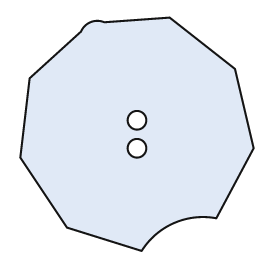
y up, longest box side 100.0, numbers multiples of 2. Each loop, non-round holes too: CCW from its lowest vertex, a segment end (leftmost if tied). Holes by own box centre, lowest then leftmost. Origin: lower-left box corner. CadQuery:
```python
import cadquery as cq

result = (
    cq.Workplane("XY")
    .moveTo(52.0, 0.0)
    .threePointArc((66.0, 12.0), (84.0, 14.0))
    .lineTo(100.0, 44.0)
    .lineTo(92.0, 78.0)
    .lineTo(64.0, 100.0)
    .lineTo(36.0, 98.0)
    .threePointArc((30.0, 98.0), (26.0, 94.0))
    .lineTo(4.0, 74.0)
    .lineTo(0.0, 40.0)
    .lineTo(20.0, 10.0)
    .close()
    .moveTo(50.0, 44.0)
    .circle(4.0)
    .moveTo(50.0, 56.0)
    .circle(4.0)
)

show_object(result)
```